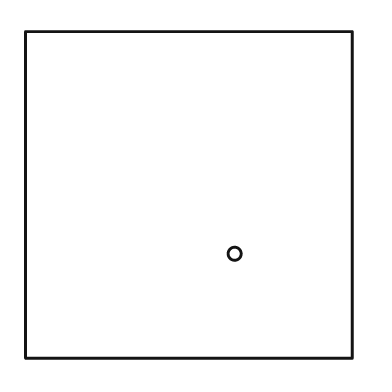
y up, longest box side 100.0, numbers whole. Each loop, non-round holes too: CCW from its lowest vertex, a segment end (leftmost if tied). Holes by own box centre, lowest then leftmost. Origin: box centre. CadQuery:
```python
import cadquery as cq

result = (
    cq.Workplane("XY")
    .moveTo(-50.0, -50.0)
    .lineTo(50.0, -50.0)
    .lineTo(50.0, 50.0)
    .lineTo(-50.0, 50.0)
    .close()
    .moveTo(14.0, -18.0)
    .circle(2.0)
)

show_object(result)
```